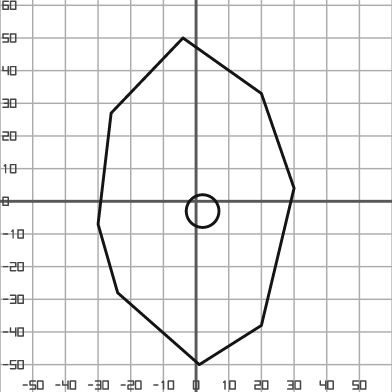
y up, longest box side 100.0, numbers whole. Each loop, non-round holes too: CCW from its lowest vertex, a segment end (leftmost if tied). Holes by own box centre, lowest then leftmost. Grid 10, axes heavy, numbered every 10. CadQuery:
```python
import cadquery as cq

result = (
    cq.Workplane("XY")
    .moveTo(1.0, -50.0)
    .lineTo(20.0, -38.0)
    .lineTo(30.0, 4.0)
    .lineTo(20.0, 33.0)
    .lineTo(-4.0, 50.0)
    .lineTo(-26.0, 27.0)
    .lineTo(-30.0, -7.0)
    .lineTo(-24.0, -28.0)
    .close()
    .moveTo(2.0, -3.0)
    .circle(5.0)
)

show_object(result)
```